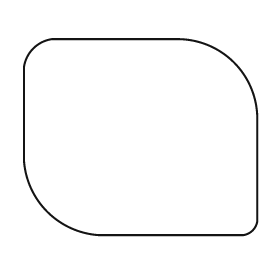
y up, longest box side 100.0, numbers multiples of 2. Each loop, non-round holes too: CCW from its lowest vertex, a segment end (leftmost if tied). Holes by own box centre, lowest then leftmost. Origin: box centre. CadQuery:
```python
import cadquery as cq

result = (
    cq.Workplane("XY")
    .moveTo(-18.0, -42.0)
    .lineTo(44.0, -42.0)
    .threePointArc((48.0, -40.0), (50.0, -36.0))
    .lineTo(50.0, 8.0)
    .threePointArc((40.0, 32.0), (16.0, 42.0))
    .lineTo(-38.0, 42.0)
    .threePointArc((-46.0, 38.0), (-50.0, 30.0))
    .lineTo(-50.0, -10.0)
    .threePointArc((-40.0, -32.0), (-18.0, -42.0))
    .close()
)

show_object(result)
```